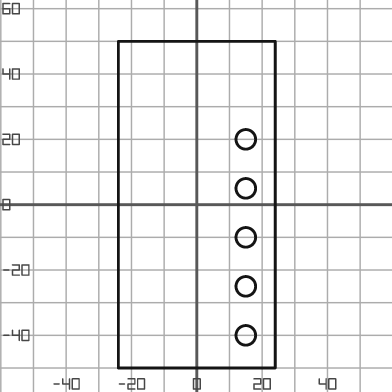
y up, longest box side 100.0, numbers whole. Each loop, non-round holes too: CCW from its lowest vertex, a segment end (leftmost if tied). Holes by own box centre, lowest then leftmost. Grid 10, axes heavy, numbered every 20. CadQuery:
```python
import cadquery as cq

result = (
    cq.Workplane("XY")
    .moveTo(-24.0, -50.0)
    .lineTo(24.0, -50.0)
    .lineTo(24.0, 50.0)
    .lineTo(-24.0, 50.0)
    .close()
    .moveTo(15.0, -40.0)
    .circle(3.0)
    .moveTo(15.0, -25.0)
    .circle(3.0)
    .moveTo(15.0, -10.0)
    .circle(3.0)
    .moveTo(15.0, 5.0)
    .circle(3.0)
    .moveTo(15.0, 20.0)
    .circle(3.0)
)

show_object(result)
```